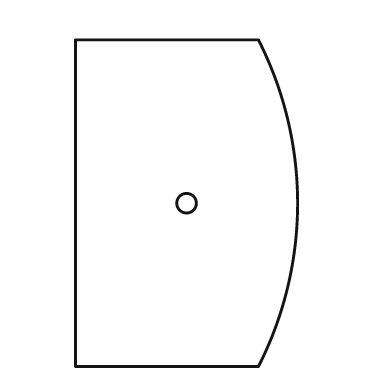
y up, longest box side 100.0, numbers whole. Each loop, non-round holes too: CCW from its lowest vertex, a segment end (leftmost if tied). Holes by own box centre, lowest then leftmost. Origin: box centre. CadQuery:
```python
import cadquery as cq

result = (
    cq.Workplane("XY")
    .moveTo(-34.0, -50.0)
    .lineTo(22.0, -50.0)
    .threePointArc((34.0, 0.0), (22.0, 50.0))
    .lineTo(-34.0, 50.0)
    .close()
    .moveTo(0.0, 0.0)
    .circle(3.0)
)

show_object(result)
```